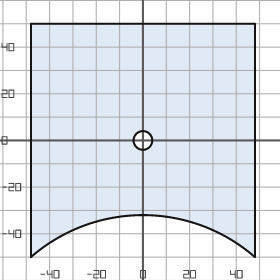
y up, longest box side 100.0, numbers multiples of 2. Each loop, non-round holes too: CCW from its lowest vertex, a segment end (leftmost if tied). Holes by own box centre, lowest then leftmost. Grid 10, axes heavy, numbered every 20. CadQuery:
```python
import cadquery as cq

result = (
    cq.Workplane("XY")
    .moveTo(-48.0, -50.0)
    .threePointArc((0.0, -32.0), (48.0, -50.0))
    .lineTo(48.0, 50.0)
    .lineTo(-48.0, 50.0)
    .close()
    .moveTo(0.0, 0.0)
    .circle(4.0)
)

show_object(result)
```